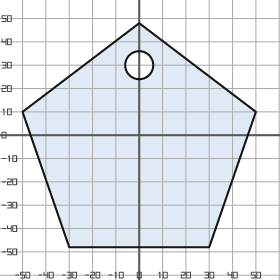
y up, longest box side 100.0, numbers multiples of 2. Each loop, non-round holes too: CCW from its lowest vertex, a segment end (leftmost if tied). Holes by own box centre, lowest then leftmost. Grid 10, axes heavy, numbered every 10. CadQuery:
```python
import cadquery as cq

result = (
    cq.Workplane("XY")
    .moveTo(-30.0, -48.0)
    .lineTo(30.0, -48.0)
    .lineTo(50.0, 10.0)
    .lineTo(0.0, 48.0)
    .lineTo(-50.0, 10.0)
    .close()
    .moveTo(0.0, 30.0)
    .circle(6.0)
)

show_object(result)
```